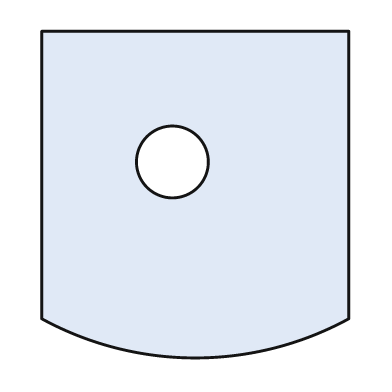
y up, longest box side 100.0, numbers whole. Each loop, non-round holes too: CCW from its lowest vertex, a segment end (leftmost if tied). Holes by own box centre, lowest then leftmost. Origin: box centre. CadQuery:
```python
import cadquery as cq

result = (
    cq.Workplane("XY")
    .moveTo(-47.0, -38.0)
    .threePointArc((0.0, -50.0), (47.0, -38.0))
    .lineTo(47.0, 50.0)
    .lineTo(-47.0, 50.0)
    .close()
    .moveTo(-7.0, 10.0)
    .circle(11.0)
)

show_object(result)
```